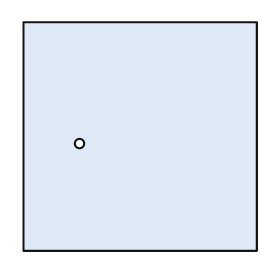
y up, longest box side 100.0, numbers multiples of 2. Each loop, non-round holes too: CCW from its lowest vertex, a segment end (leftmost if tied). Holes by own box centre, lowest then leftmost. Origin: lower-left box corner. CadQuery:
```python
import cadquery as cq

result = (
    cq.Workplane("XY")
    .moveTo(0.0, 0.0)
    .lineTo(100.0, 0.0)
    .lineTo(100.0, 98.0)
    .lineTo(0.0, 98.0)
    .close()
    .moveTo(24.0, 46.0)
    .circle(2.0)
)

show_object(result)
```